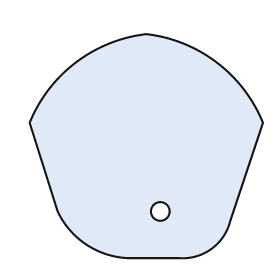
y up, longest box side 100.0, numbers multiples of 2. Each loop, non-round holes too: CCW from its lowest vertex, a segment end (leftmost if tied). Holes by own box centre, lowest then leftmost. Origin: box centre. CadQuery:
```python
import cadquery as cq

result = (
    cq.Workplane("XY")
    .moveTo(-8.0, -48.0)
    .lineTo(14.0, -48.0)
    .threePointArc((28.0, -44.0), (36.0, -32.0))
    .lineTo(50.0, 10.0)
    .threePointArc((30.0, 36.0), (0.0, 48.0))
    .threePointArc((-30.0, 36.0), (-50.0, 10.0))
    .lineTo(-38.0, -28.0)
    .threePointArc((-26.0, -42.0), (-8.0, -48.0))
    .close()
    .moveTo(6.0, -28.0)
    .circle(4.0)
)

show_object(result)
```